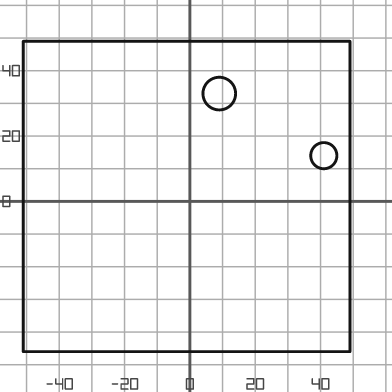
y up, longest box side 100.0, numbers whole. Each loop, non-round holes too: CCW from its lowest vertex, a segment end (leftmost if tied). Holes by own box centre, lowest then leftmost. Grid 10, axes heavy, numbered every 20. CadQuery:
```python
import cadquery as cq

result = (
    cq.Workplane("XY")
    .moveTo(-51.0, -46.0)
    .lineTo(49.0, -46.0)
    .lineTo(49.0, 49.0)
    .lineTo(-51.0, 49.0)
    .close()
    .moveTo(41.0, 14.0)
    .circle(4.0)
    .moveTo(9.0, 33.0)
    .circle(5.0)
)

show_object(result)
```